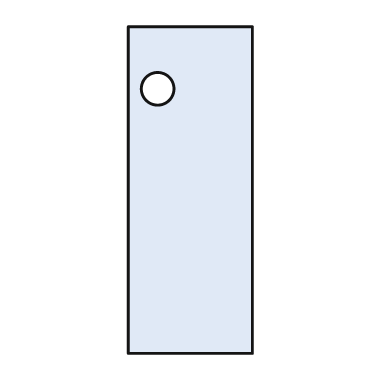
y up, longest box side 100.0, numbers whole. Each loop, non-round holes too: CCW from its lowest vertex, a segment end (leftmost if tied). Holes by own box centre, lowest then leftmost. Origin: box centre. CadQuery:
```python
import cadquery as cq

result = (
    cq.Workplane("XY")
    .moveTo(-19.0, -50.0)
    .lineTo(19.0, -50.0)
    .lineTo(19.0, 50.0)
    .lineTo(-19.0, 50.0)
    .close()
    .moveTo(-10.0, 31.0)
    .circle(5.0)
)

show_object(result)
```